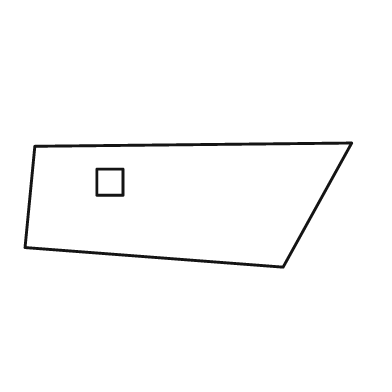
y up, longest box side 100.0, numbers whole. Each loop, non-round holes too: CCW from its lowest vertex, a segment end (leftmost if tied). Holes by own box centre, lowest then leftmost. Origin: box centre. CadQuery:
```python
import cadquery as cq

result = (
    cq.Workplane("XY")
    .moveTo(29.0, -19.0)
    .lineTo(50.0, 19.0)
    .lineTo(-47.0, 18.0)
    .lineTo(-50.0, -13.0)
    .close()
    .moveTo(-28.0, 3.0)
    .lineTo(-20.0, 3.0)
    .lineTo(-20.0, 11.0)
    .lineTo(-28.0, 11.0)
    .close()
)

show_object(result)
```